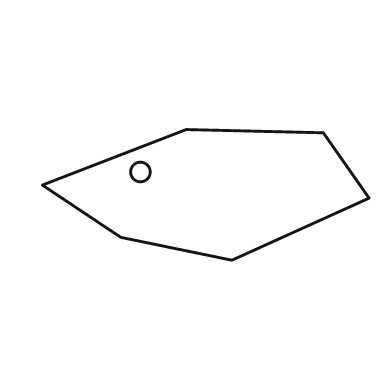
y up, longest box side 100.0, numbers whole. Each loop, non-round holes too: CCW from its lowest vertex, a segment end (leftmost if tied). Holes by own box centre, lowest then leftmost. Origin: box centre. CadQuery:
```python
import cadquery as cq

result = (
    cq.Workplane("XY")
    .moveTo(8.0, -20.0)
    .lineTo(50.0, -1.0)
    .lineTo(36.0, 19.0)
    .lineTo(-6.0, 20.0)
    .lineTo(-50.0, 3.0)
    .lineTo(-26.0, -13.0)
    .close()
    .moveTo(-20.0, 7.0)
    .circle(3.0)
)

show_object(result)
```